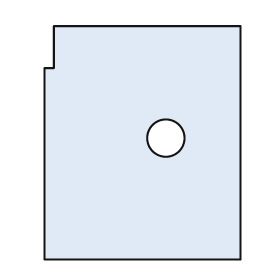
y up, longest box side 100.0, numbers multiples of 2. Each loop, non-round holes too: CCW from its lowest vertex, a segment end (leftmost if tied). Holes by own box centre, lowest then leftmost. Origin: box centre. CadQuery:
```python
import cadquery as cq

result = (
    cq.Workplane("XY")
    .moveTo(-42.0, -50.0)
    .lineTo(42.0, -50.0)
    .lineTo(42.0, 50.0)
    .lineTo(-38.0, 50.0)
    .lineTo(-38.0, 32.0)
    .lineTo(-42.0, 32.0)
    .close()
    .moveTo(10.0, 2.0)
    .circle(8.0)
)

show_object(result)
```